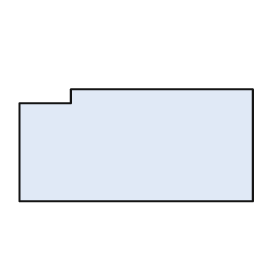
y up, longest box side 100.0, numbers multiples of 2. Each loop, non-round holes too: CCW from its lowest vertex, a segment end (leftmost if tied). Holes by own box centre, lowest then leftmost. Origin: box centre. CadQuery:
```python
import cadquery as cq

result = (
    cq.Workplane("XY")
    .moveTo(-50.0, -24.0)
    .lineTo(50.0, -24.0)
    .lineTo(50.0, 24.0)
    .lineTo(-28.0, 24.0)
    .lineTo(-28.0, 18.0)
    .lineTo(-50.0, 18.0)
    .close()
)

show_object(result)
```